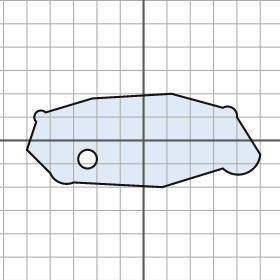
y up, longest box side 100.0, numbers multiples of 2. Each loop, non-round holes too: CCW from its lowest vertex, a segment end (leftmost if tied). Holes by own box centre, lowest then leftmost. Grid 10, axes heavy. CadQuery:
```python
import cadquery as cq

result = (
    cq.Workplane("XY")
    .moveTo(8.0, -20.0)
    .lineTo(34.0, -12.0)
    .threePointArc((44.0, -14.0), (50.0, -6.0))
    .lineTo(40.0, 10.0)
    .threePointArc((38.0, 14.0), (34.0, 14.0))
    .lineTo(12.0, 20.0)
    .lineTo(-22.0, 18.0)
    .lineTo(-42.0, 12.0)
    .threePointArc((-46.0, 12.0), (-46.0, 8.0))
    .lineTo(-50.0, -4.0)
    .lineTo(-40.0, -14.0)
    .threePointArc((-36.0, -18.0), (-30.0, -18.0))
    .close()
    .moveTo(-24.0, -8.0)
    .circle(4.0)
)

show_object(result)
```